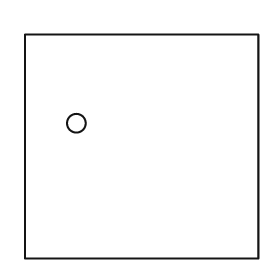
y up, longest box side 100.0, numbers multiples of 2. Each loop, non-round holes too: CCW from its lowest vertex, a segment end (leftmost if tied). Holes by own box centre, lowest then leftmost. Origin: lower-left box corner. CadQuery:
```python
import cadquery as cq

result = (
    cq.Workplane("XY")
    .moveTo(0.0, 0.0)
    .lineTo(100.0, 0.0)
    .lineTo(100.0, 96.0)
    .lineTo(0.0, 96.0)
    .close()
    .moveTo(22.0, 58.0)
    .circle(4.0)
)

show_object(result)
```